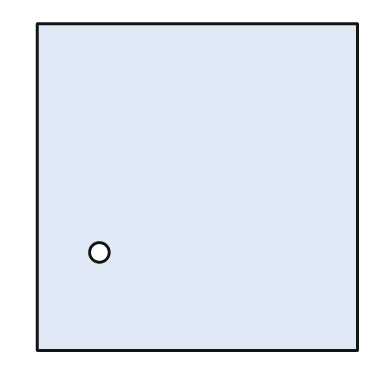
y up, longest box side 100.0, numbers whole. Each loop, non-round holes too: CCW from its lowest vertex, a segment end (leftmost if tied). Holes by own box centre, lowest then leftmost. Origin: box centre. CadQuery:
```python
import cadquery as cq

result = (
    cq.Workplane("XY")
    .moveTo(-49.0, -50.0)
    .lineTo(49.0, -50.0)
    .lineTo(49.0, 50.0)
    .lineTo(-49.0, 50.0)
    .close()
    .moveTo(-30.0, -20.0)
    .circle(3.0)
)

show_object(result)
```